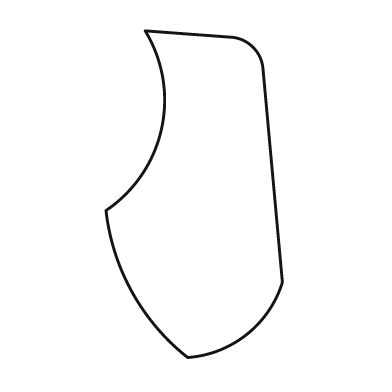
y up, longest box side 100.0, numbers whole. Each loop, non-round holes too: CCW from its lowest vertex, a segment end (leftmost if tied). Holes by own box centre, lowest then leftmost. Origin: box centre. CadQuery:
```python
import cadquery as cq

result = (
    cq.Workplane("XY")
    .moveTo(-2.0, -50.0)
    .threePointArc((16.0, -43.0), (27.0, -27.0))
    .lineTo(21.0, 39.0)
    .threePointArc((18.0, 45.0), (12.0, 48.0))
    .lineTo(-15.0, 50.0)
    .threePointArc((-10.0, 20.0), (-27.0, -5.0))
    .threePointArc((-19.0, -30.0), (-2.0, -50.0))
    .close()
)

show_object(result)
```